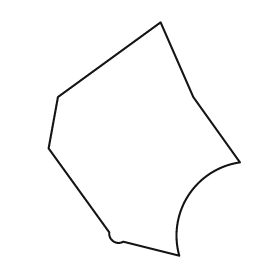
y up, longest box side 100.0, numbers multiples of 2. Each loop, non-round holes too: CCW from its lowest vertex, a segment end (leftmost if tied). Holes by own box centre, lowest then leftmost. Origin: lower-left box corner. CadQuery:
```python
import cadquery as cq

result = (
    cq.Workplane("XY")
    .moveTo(56.0, 0.0)
    .threePointArc((60.0, 26.0), (82.0, 40.0))
    .lineTo(62.0, 68.0)
    .lineTo(48.0, 100.0)
    .lineTo(4.0, 68.0)
    .lineTo(0.0, 46.0)
    .lineTo(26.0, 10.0)
    .threePointArc((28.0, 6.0), (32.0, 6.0))
    .close()
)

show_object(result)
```